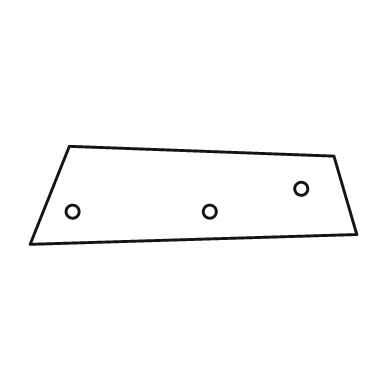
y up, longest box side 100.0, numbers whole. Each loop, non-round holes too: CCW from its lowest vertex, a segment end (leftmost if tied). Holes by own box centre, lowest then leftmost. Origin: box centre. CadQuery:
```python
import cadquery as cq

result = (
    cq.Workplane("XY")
    .moveTo(-50.0, -15.0)
    .lineTo(50.0, -12.0)
    .lineTo(43.0, 12.0)
    .lineTo(-38.0, 15.0)
    .close()
    .moveTo(-37.0, -5.0)
    .circle(2.0)
    .moveTo(5.0, -5.0)
    .circle(2.0)
    .moveTo(33.0, 2.0)
    .circle(2.0)
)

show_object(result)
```